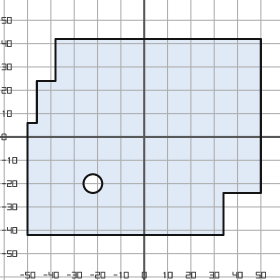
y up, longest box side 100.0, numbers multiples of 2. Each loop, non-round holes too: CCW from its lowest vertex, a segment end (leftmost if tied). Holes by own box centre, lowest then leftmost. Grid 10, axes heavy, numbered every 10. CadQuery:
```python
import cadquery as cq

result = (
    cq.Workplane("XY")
    .moveTo(-50.0, -42.0)
    .lineTo(34.0, -42.0)
    .lineTo(34.0, -24.0)
    .lineTo(50.0, -24.0)
    .lineTo(50.0, 42.0)
    .lineTo(-38.0, 42.0)
    .lineTo(-38.0, 24.0)
    .lineTo(-46.0, 24.0)
    .lineTo(-46.0, 6.0)
    .lineTo(-50.0, 6.0)
    .close()
    .moveTo(-22.0, -20.0)
    .circle(4.0)
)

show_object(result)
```